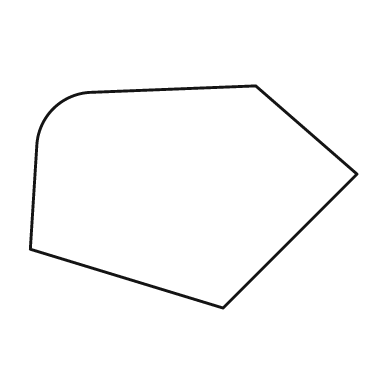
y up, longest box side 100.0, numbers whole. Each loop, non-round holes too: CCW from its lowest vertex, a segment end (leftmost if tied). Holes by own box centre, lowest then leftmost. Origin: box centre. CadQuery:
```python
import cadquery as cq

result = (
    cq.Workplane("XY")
    .moveTo(9.0, -34.0)
    .lineTo(50.0, 7.0)
    .lineTo(19.0, 34.0)
    .lineTo(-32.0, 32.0)
    .threePointArc((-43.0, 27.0), (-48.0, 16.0))
    .lineTo(-50.0, -16.0)
    .close()
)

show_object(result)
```